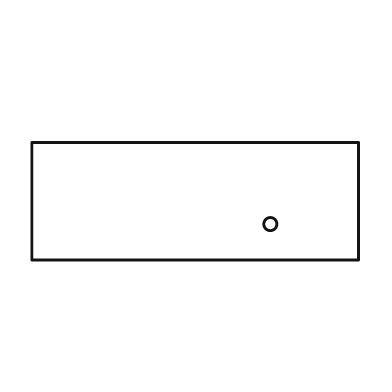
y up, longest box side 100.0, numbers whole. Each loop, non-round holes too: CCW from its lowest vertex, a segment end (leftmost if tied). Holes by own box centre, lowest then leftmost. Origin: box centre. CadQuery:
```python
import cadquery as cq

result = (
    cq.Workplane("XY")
    .moveTo(-50.0, -18.0)
    .lineTo(50.0, -18.0)
    .lineTo(50.0, 18.0)
    .lineTo(-50.0, 18.0)
    .close()
    .moveTo(23.0, -7.0)
    .circle(2.0)
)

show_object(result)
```